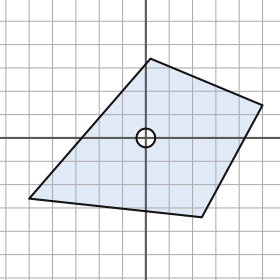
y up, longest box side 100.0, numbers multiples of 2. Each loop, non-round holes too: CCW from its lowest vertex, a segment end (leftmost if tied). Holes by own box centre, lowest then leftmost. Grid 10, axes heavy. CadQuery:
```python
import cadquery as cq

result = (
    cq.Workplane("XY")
    .moveTo(24.0, -34.0)
    .lineTo(50.0, 14.0)
    .lineTo(2.0, 34.0)
    .lineTo(-50.0, -26.0)
    .close()
    .moveTo(0.0, 0.0)
    .circle(4.0)
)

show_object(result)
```